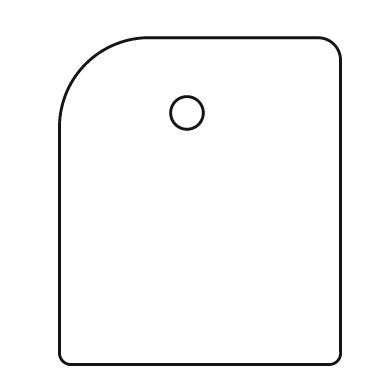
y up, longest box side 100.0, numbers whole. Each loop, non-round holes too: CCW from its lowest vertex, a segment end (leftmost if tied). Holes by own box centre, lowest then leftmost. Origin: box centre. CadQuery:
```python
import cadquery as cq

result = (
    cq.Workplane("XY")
    .moveTo(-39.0, -50.0)
    .lineTo(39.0, -50.0)
    .threePointArc((42.0, -49.0), (43.0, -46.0))
    .lineTo(43.0, 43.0)
    .threePointArc((41.0, 48.0), (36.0, 50.0))
    .lineTo(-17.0, 50.0)
    .threePointArc((-35.0, 42.0), (-43.0, 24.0))
    .lineTo(-43.0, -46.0)
    .threePointArc((-42.0, -49.0), (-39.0, -50.0))
    .close()
    .moveTo(-4.0, 27.0)
    .circle(5.0)
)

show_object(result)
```